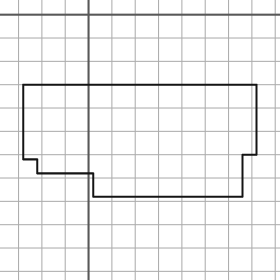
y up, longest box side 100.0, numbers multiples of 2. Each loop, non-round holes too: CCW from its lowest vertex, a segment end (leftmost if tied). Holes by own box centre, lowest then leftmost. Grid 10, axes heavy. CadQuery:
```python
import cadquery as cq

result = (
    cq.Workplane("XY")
    .moveTo(2.0, -78.0)
    .lineTo(66.0, -78.0)
    .lineTo(66.0, -60.0)
    .lineTo(72.0, -60.0)
    .lineTo(72.0, -30.0)
    .lineTo(-28.0, -30.0)
    .lineTo(-28.0, -62.0)
    .lineTo(-22.0, -62.0)
    .lineTo(-22.0, -68.0)
    .lineTo(2.0, -68.0)
    .close()
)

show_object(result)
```